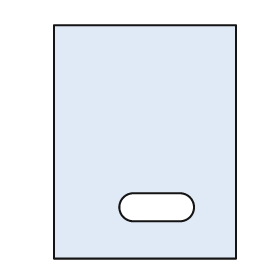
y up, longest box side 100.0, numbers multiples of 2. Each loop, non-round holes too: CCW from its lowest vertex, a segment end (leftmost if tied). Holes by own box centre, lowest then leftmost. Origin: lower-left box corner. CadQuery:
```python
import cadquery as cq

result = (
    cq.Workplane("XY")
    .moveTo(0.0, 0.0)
    .lineTo(78.0, 0.0)
    .lineTo(78.0, 100.0)
    .lineTo(0.0, 100.0)
    .close()
    .moveTo(34.0, 16.0)
    .lineTo(54.0, 16.0)
    .threePointArc((60.0, 22.0), (54.0, 28.0))
    .lineTo(34.0, 28.0)
    .threePointArc((28.0, 22.0), (34.0, 16.0))
    .close()
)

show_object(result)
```